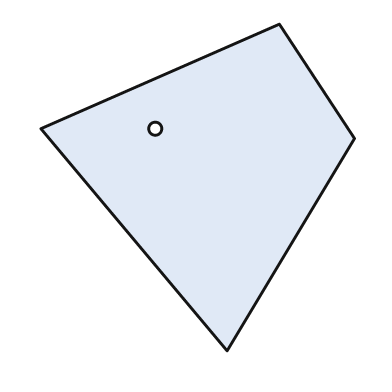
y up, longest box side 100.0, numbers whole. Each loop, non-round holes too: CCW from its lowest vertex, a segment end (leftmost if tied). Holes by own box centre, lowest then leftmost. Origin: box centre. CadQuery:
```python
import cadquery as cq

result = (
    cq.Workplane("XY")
    .moveTo(9.0, -50.0)
    .lineTo(48.0, 15.0)
    .lineTo(25.0, 50.0)
    .lineTo(-48.0, 18.0)
    .close()
    .moveTo(-13.0, 18.0)
    .circle(2.0)
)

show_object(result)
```